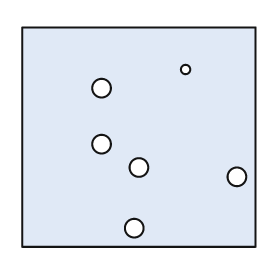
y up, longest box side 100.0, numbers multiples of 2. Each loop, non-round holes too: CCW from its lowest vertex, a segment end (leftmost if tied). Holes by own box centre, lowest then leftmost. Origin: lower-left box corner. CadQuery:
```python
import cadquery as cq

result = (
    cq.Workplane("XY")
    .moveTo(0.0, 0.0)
    .lineTo(100.0, 0.0)
    .lineTo(100.0, 94.0)
    .lineTo(0.0, 94.0)
    .close()
    .moveTo(48.0, 8.0)
    .circle(4.0)
    .moveTo(92.0, 30.0)
    .circle(4.0)
    .moveTo(50.0, 34.0)
    .circle(4.0)
    .moveTo(34.0, 44.0)
    .circle(4.0)
    .moveTo(34.0, 68.0)
    .circle(4.0)
    .moveTo(70.0, 76.0)
    .circle(2.0)
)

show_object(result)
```